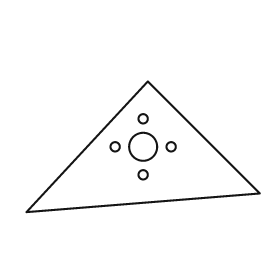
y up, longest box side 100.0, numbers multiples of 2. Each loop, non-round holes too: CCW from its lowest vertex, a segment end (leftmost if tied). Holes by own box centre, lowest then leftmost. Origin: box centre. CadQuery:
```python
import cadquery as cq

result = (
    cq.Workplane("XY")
    .moveTo(-50.0, -28.0)
    .lineTo(50.0, -20.0)
    .lineTo(2.0, 28.0)
    .close()
    .moveTo(0.0, -12.0)
    .circle(2.0)
    .moveTo(-12.0, 0.0)
    .circle(2.0)
    .moveTo(0.0, 0.0)
    .circle(6.0)
    .moveTo(12.0, 0.0)
    .circle(2.0)
    .moveTo(0.0, 12.0)
    .circle(2.0)
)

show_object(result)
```